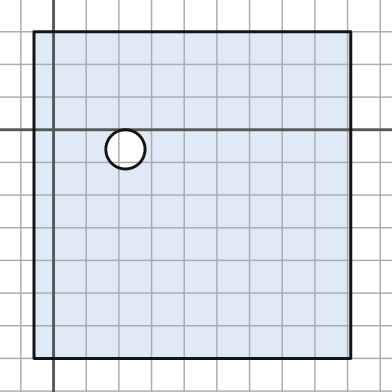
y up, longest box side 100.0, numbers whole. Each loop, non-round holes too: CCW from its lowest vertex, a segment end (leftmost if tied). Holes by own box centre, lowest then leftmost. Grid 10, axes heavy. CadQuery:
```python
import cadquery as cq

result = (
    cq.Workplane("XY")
    .moveTo(-6.0, -70.0)
    .lineTo(91.0, -70.0)
    .lineTo(91.0, 30.0)
    .lineTo(-6.0, 30.0)
    .close()
    .moveTo(22.0, -6.0)
    .circle(6.0)
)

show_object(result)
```